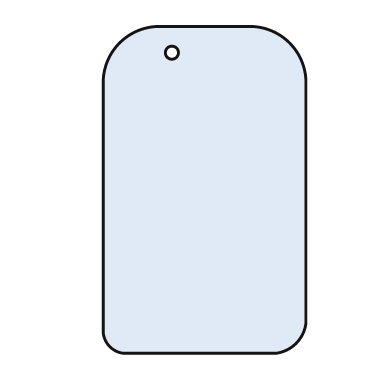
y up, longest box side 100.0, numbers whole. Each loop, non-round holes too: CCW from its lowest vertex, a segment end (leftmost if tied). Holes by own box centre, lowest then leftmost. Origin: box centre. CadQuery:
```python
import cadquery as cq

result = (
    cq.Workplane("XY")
    .moveTo(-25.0, -50.0)
    .lineTo(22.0, -50.0)
    .threePointArc((28.0, -47.0), (31.0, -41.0))
    .lineTo(31.0, 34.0)
    .threePointArc((26.0, 45.0), (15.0, 50.0))
    .lineTo(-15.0, 50.0)
    .threePointArc((-26.0, 45.0), (-31.0, 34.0))
    .lineTo(-31.0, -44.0)
    .threePointArc((-29.0, -48.0), (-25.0, -50.0))
    .close()
    .moveTo(-10.0, 42.0)
    .circle(2.0)
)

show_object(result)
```